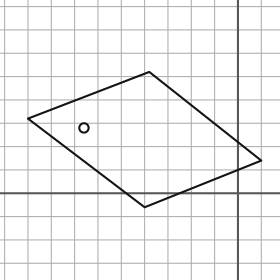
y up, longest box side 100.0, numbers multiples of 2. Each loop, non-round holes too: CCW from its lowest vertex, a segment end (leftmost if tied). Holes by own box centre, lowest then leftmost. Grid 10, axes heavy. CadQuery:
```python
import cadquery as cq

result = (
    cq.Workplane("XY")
    .moveTo(-40.0, -6.0)
    .lineTo(10.0, 14.0)
    .lineTo(-38.0, 52.0)
    .lineTo(-90.0, 32.0)
    .close()
    .moveTo(-66.0, 28.0)
    .circle(2.0)
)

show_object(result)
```